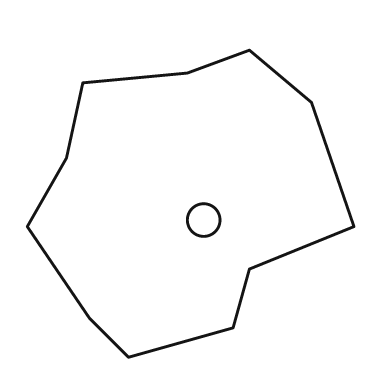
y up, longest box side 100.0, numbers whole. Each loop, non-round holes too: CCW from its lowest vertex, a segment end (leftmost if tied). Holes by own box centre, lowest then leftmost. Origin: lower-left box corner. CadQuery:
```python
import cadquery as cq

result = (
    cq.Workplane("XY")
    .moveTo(31.0, 0.0)
    .lineTo(63.0, 9.0)
    .lineTo(68.0, 27.0)
    .lineTo(100.0, 40.0)
    .lineTo(87.0, 78.0)
    .lineTo(68.0, 94.0)
    .lineTo(49.0, 87.0)
    .lineTo(17.0, 84.0)
    .lineTo(12.0, 61.0)
    .lineTo(0.0, 40.0)
    .lineTo(19.0, 12.0)
    .close()
    .moveTo(54.0, 42.0)
    .circle(5.0)
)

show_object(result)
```